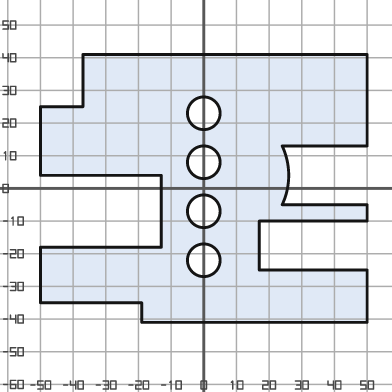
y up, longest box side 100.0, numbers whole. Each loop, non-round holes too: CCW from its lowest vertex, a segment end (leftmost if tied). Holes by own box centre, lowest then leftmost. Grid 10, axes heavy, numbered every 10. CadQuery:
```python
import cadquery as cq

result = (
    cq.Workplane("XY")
    .moveTo(-19.0, -41.0)
    .lineTo(50.0, -41.0)
    .lineTo(50.0, -25.0)
    .lineTo(17.0, -25.0)
    .lineTo(17.0, -10.0)
    .lineTo(50.0, -10.0)
    .lineTo(50.0, -5.0)
    .lineTo(24.0, -5.0)
    .threePointArc((26.0, 4.0), (24.0, 13.0))
    .lineTo(50.0, 13.0)
    .lineTo(50.0, 41.0)
    .lineTo(-37.0, 41.0)
    .lineTo(-37.0, 25.0)
    .lineTo(-50.0, 25.0)
    .lineTo(-50.0, 4.0)
    .lineTo(-13.0, 4.0)
    .lineTo(-13.0, -18.0)
    .lineTo(-50.0, -18.0)
    .lineTo(-50.0, -35.0)
    .lineTo(-19.0, -35.0)
    .close()
    .moveTo(0.0, -22.0)
    .circle(5.0)
    .moveTo(0.0, -7.0)
    .circle(5.0)
    .moveTo(0.0, 8.0)
    .circle(5.0)
    .moveTo(0.0, 23.0)
    .circle(5.0)
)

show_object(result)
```